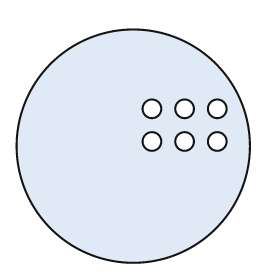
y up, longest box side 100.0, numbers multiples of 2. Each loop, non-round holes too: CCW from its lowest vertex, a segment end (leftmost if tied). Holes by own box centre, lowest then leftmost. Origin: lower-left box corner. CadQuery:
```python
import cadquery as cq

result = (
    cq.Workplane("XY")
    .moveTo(50.0, 50.0)
    .circle(50.0)
    .moveTo(58.0, 52.0)
    .circle(4.0)
    .moveTo(72.0, 52.0)
    .circle(4.0)
    .moveTo(86.0, 52.0)
    .circle(4.0)
    .moveTo(58.0, 66.0)
    .circle(4.0)
    .moveTo(72.0, 66.0)
    .circle(4.0)
    .moveTo(86.0, 66.0)
    .circle(4.0)
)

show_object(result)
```